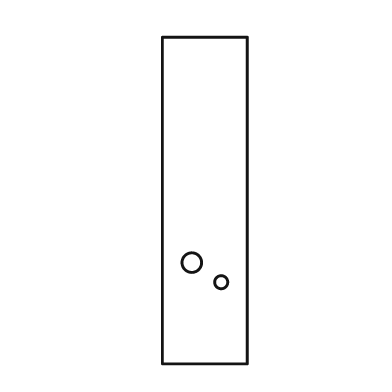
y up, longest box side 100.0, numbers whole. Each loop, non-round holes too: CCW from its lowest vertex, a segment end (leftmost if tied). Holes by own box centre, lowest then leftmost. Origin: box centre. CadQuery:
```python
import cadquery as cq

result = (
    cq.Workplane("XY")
    .moveTo(-13.0, -50.0)
    .lineTo(13.0, -50.0)
    .lineTo(13.0, 50.0)
    .lineTo(-13.0, 50.0)
    .close()
    .moveTo(5.0, -25.0)
    .circle(2.0)
    .moveTo(-4.0, -19.0)
    .circle(3.0)
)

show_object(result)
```